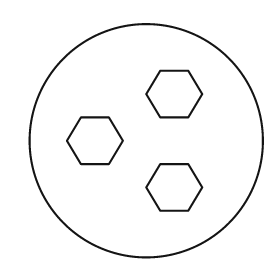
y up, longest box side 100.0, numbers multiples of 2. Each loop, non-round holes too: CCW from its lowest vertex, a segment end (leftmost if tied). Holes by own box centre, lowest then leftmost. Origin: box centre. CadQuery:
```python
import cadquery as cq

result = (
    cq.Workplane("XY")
    .moveTo(0.0, 0.0)
    .circle(50.0)
    .moveTo(6.0, -30.0)
    .lineTo(18.0, -30.0)
    .lineTo(24.0, -20.0)
    .lineTo(18.0, -10.0)
    .lineTo(6.0, -10.0)
    .lineTo(0.0, -20.0)
    .close()
    .moveTo(-28.0, -10.0)
    .lineTo(-16.0, -10.0)
    .lineTo(-10.0, 0.0)
    .lineTo(-16.0, 10.0)
    .lineTo(-28.0, 10.0)
    .lineTo(-34.0, 0.0)
    .close()
    .moveTo(6.0, 10.0)
    .lineTo(18.0, 10.0)
    .lineTo(24.0, 20.0)
    .lineTo(18.0, 30.0)
    .lineTo(6.0, 30.0)
    .lineTo(0.0, 20.0)
    .close()
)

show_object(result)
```